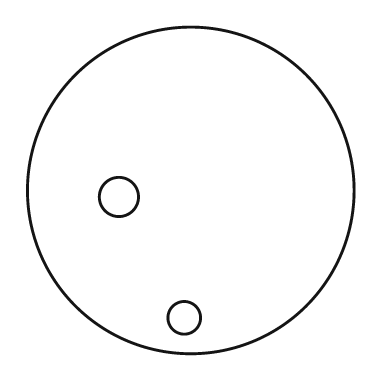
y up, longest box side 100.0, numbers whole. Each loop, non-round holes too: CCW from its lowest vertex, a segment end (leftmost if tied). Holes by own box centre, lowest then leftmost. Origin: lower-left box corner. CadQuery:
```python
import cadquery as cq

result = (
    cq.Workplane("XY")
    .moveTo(50.0, 50.0)
    .circle(50.0)
    .moveTo(48.0, 11.0)
    .circle(5.0)
    .moveTo(28.0, 48.0)
    .circle(6.0)
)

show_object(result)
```